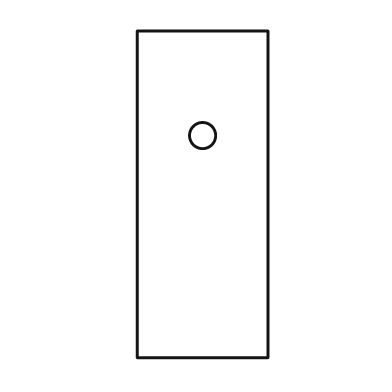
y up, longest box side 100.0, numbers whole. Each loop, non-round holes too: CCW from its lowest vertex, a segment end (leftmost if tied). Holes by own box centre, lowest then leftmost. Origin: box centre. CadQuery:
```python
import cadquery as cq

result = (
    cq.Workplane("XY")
    .moveTo(-20.0, -50.0)
    .lineTo(20.0, -50.0)
    .lineTo(20.0, 50.0)
    .lineTo(-20.0, 50.0)
    .close()
    .moveTo(0.0, 18.0)
    .circle(4.0)
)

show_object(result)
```